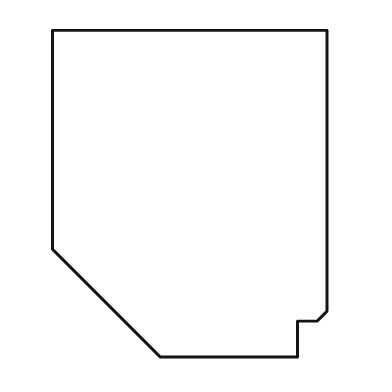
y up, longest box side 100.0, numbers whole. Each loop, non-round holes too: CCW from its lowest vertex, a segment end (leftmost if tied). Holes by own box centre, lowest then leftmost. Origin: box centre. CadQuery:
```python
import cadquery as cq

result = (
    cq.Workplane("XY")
    .moveTo(-9.0, -50.0)
    .lineTo(33.0, -50.0)
    .lineTo(33.0, -39.0)
    .lineTo(39.0, -39.0)
    .lineTo(42.0, -36.0)
    .lineTo(42.0, 50.0)
    .lineTo(-42.0, 50.0)
    .lineTo(-42.0, -17.0)
    .close()
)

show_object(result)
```